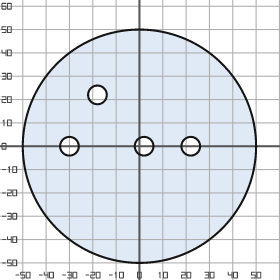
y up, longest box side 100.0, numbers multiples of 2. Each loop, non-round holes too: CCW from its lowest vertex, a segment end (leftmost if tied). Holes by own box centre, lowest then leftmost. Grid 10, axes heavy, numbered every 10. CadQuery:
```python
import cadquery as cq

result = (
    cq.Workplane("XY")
    .moveTo(0.0, 0.0)
    .circle(50.0)
    .moveTo(-30.0, 0.0)
    .circle(4.0)
    .moveTo(2.0, 0.0)
    .circle(4.0)
    .moveTo(22.0, 0.0)
    .circle(4.0)
    .moveTo(-18.0, 22.0)
    .circle(4.0)
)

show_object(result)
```